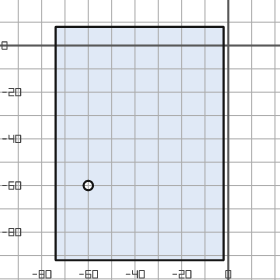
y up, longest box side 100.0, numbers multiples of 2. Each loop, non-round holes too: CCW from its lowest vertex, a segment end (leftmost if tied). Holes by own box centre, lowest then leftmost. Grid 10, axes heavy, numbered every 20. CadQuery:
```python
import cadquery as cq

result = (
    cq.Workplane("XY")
    .moveTo(-74.0, -92.0)
    .lineTo(-2.0, -92.0)
    .lineTo(-2.0, 8.0)
    .lineTo(-74.0, 8.0)
    .close()
    .moveTo(-60.0, -60.0)
    .circle(2.0)
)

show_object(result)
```